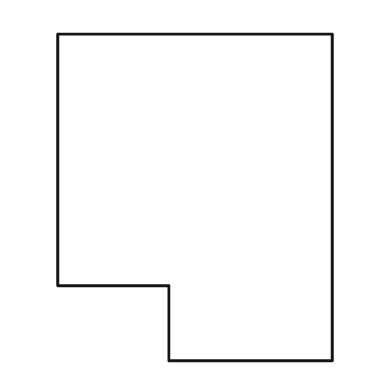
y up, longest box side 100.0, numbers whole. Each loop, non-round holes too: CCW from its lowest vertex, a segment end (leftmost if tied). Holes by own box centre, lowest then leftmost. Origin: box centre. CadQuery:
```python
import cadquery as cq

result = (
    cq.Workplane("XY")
    .moveTo(-8.0, -50.0)
    .lineTo(42.0, -50.0)
    .lineTo(42.0, 50.0)
    .lineTo(-42.0, 50.0)
    .lineTo(-42.0, -27.0)
    .lineTo(-8.0, -27.0)
    .close()
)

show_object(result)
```